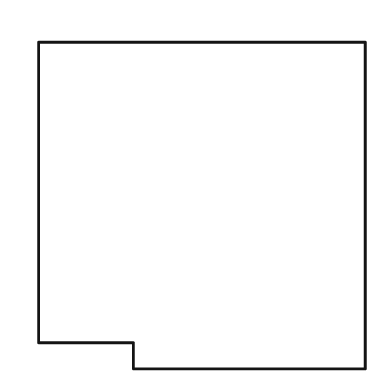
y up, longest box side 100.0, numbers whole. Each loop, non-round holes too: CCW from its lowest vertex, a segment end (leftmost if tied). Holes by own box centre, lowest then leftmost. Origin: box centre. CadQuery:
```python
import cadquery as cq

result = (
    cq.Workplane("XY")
    .moveTo(-21.0, -50.0)
    .lineTo(50.0, -50.0)
    .lineTo(50.0, 50.0)
    .lineTo(-50.0, 50.0)
    .lineTo(-50.0, -42.0)
    .lineTo(-21.0, -42.0)
    .close()
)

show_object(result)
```